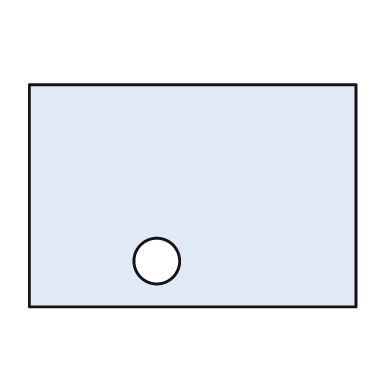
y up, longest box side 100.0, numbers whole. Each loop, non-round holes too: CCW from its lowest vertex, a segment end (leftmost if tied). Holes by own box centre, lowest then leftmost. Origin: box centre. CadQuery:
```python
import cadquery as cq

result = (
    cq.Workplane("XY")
    .moveTo(-50.0, -34.0)
    .lineTo(50.0, -34.0)
    .lineTo(50.0, 34.0)
    .lineTo(-50.0, 34.0)
    .close()
    .moveTo(-11.0, -20.0)
    .circle(7.0)
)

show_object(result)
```